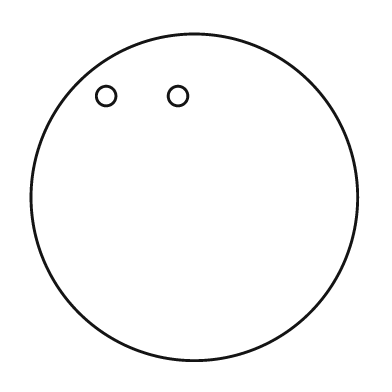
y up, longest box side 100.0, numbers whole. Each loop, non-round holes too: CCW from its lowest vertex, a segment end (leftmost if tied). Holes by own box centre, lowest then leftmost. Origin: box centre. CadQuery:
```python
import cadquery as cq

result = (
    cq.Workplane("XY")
    .moveTo(0.0, 0.0)
    .circle(50.0)
    .moveTo(-27.0, 31.0)
    .circle(3.0)
    .moveTo(-5.0, 31.0)
    .circle(3.0)
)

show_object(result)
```